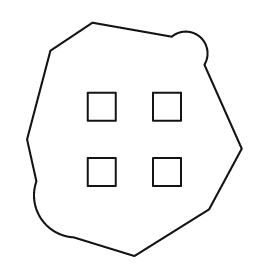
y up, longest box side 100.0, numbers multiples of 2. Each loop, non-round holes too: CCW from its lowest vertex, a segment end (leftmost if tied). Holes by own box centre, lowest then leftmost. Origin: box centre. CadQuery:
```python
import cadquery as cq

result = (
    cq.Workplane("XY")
    .moveTo(0.0, -50.0)
    .lineTo(32.0, -30.0)
    .lineTo(46.0, -4.0)
    .lineTo(30.0, 32.0)
    .threePointArc((28.0, 44.0), (16.0, 44.0))
    .lineTo(-18.0, 50.0)
    .lineTo(-36.0, 38.0)
    .lineTo(-46.0, 0.0)
    .lineTo(-42.0, -18.0)
    .threePointArc((-40.0, -34.0), (-26.0, -42.0))
    .close()
    .moveTo(-20.0, -20.0)
    .lineTo(-8.0, -20.0)
    .lineTo(-8.0, -8.0)
    .lineTo(-20.0, -8.0)
    .close()
    .moveTo(8.0, -20.0)
    .lineTo(20.0, -20.0)
    .lineTo(20.0, -8.0)
    .lineTo(8.0, -8.0)
    .close()
    .moveTo(-20.0, 8.0)
    .lineTo(-8.0, 8.0)
    .lineTo(-8.0, 20.0)
    .lineTo(-20.0, 20.0)
    .close()
    .moveTo(8.0, 8.0)
    .lineTo(20.0, 8.0)
    .lineTo(20.0, 20.0)
    .lineTo(8.0, 20.0)
    .close()
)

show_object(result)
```